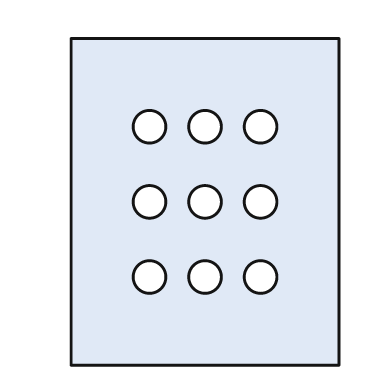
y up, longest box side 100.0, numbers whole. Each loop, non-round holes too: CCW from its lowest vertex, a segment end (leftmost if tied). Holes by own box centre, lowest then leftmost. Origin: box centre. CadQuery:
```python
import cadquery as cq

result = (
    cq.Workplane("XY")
    .moveTo(-41.0, -50.0)
    .lineTo(41.0, -50.0)
    .lineTo(41.0, 50.0)
    .lineTo(-41.0, 50.0)
    .close()
    .moveTo(-17.0, -23.0)
    .circle(5.0)
    .moveTo(0.0, -23.0)
    .circle(5.0)
    .moveTo(17.0, -23.0)
    .circle(5.0)
    .moveTo(-17.0, 0.0)
    .circle(5.0)
    .moveTo(0.0, 0.0)
    .circle(5.0)
    .moveTo(17.0, 0.0)
    .circle(5.0)
    .moveTo(-17.0, 23.0)
    .circle(5.0)
    .moveTo(0.0, 23.0)
    .circle(5.0)
    .moveTo(17.0, 23.0)
    .circle(5.0)
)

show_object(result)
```